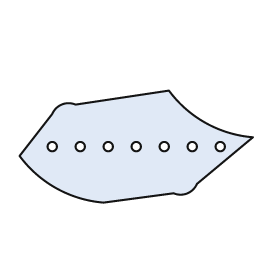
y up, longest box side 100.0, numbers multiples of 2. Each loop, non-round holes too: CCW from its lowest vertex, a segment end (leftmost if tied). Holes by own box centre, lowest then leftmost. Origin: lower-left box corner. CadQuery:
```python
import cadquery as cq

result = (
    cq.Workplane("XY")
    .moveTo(36.0, 0.0)
    .lineTo(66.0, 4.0)
    .threePointArc((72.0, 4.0), (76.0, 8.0))
    .lineTo(100.0, 28.0)
    .threePointArc((80.0, 34.0), (64.0, 48.0))
    .lineTo(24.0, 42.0)
    .threePointArc((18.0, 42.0), (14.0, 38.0))
    .lineTo(0.0, 20.0)
    .threePointArc((16.0, 6.0), (36.0, 0.0))
    .close()
    .moveTo(14.0, 24.0)
    .circle(2.0)
    .moveTo(26.0, 24.0)
    .circle(2.0)
    .moveTo(38.0, 24.0)
    .circle(2.0)
    .moveTo(50.0, 24.0)
    .circle(2.0)
    .moveTo(62.0, 24.0)
    .circle(2.0)
    .moveTo(74.0, 24.0)
    .circle(2.0)
    .moveTo(86.0, 24.0)
    .circle(2.0)
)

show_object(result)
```